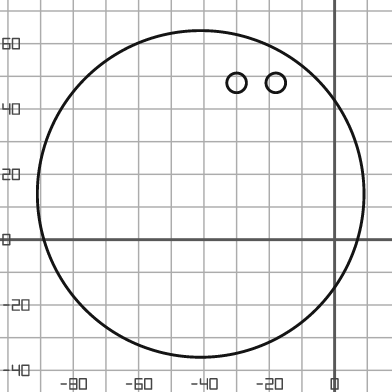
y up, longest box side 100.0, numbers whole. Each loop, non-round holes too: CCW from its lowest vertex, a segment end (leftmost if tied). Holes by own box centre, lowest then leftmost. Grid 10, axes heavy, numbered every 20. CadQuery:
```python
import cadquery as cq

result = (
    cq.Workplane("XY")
    .moveTo(-41.0, 14.0)
    .circle(50.0)
    .moveTo(-30.0, 48.0)
    .circle(3.0)
    .moveTo(-18.0, 48.0)
    .circle(3.0)
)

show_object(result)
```